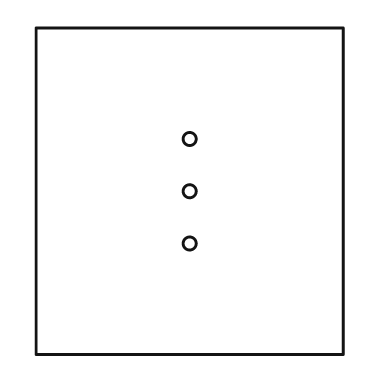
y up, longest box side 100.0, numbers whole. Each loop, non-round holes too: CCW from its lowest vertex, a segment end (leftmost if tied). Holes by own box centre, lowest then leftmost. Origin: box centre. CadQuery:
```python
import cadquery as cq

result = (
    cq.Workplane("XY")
    .moveTo(-47.0, -50.0)
    .lineTo(47.0, -50.0)
    .lineTo(47.0, 50.0)
    .lineTo(-47.0, 50.0)
    .close()
    .moveTo(0.0, -16.0)
    .circle(2.0)
    .moveTo(0.0, 0.0)
    .circle(2.0)
    .moveTo(0.0, 16.0)
    .circle(2.0)
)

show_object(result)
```